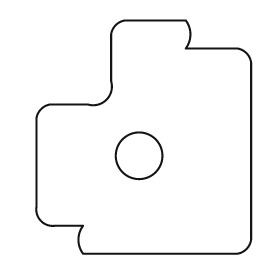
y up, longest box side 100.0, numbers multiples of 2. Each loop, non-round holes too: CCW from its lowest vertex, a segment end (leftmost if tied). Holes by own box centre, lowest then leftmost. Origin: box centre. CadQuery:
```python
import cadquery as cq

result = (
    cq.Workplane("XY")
    .moveTo(-26.0, -50.0)
    .lineTo(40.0, -50.0)
    .threePointArc((44.0, -48.0), (46.0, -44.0))
    .lineTo(46.0, 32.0)
    .threePointArc((44.0, 36.0), (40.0, 38.0))
    .lineTo(18.0, 38.0)
    .threePointArc((20.0, 44.0), (18.0, 50.0))
    .lineTo(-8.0, 50.0)
    .threePointArc((-12.0, 48.0), (-14.0, 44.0))
    .lineTo(-14.0, 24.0)
    .threePointArc((-16.0, 16.0), (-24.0, 14.0))
    .lineTo(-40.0, 14.0)
    .threePointArc((-44.0, 12.0), (-46.0, 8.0))
    .lineTo(-46.0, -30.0)
    .threePointArc((-44.0, -36.0), (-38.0, -38.0))
    .lineTo(-26.0, -38.0)
    .threePointArc((-28.0, -44.0), (-26.0, -50.0))
    .close()
    .moveTo(-2.0, -8.0)
    .circle(10.0)
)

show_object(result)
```